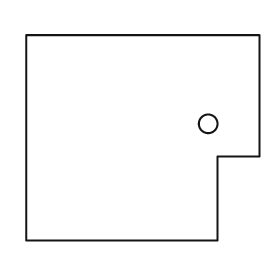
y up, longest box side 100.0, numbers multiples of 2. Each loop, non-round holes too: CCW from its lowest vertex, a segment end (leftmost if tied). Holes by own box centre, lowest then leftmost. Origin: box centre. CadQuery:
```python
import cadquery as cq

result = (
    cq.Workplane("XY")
    .moveTo(-50.0, -44.0)
    .lineTo(32.0, -44.0)
    .lineTo(32.0, -8.0)
    .lineTo(50.0, -8.0)
    .lineTo(50.0, 44.0)
    .lineTo(-50.0, 44.0)
    .close()
    .moveTo(28.0, 6.0)
    .circle(4.0)
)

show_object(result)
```